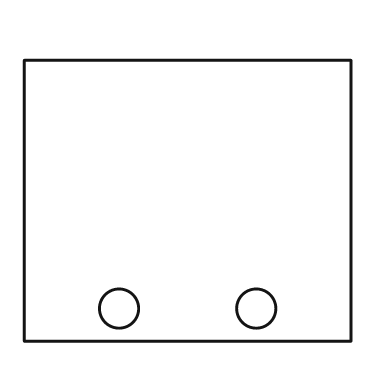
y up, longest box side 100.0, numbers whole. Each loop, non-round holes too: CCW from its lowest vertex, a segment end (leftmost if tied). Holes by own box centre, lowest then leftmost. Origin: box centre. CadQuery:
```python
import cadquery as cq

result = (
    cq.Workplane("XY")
    .moveTo(-50.0, -43.0)
    .lineTo(50.0, -43.0)
    .lineTo(50.0, 43.0)
    .lineTo(-50.0, 43.0)
    .close()
    .moveTo(-21.0, -33.0)
    .circle(6.0)
    .moveTo(21.0, -33.0)
    .circle(6.0)
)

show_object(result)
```